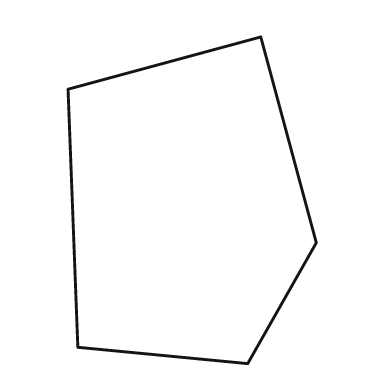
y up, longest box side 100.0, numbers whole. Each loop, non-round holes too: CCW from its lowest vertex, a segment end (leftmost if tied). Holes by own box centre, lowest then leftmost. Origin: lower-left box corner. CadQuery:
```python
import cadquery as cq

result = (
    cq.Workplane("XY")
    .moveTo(55.0, 0.0)
    .lineTo(76.0, 37.0)
    .lineTo(59.0, 100.0)
    .lineTo(0.0, 84.0)
    .lineTo(3.0, 5.0)
    .close()
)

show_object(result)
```